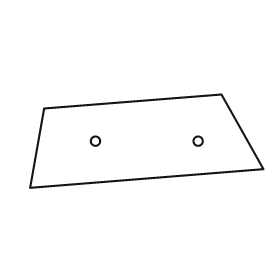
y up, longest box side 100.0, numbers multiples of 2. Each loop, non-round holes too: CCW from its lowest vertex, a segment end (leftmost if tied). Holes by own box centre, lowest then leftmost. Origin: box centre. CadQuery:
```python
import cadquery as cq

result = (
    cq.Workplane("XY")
    .moveTo(-50.0, -20.0)
    .lineTo(50.0, -12.0)
    .lineTo(32.0, 20.0)
    .lineTo(-44.0, 14.0)
    .close()
    .moveTo(-22.0, 0.0)
    .circle(2.0)
    .moveTo(22.0, 0.0)
    .circle(2.0)
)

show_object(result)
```